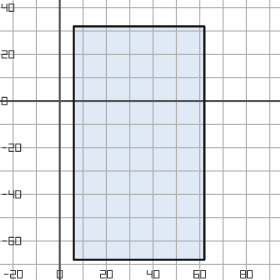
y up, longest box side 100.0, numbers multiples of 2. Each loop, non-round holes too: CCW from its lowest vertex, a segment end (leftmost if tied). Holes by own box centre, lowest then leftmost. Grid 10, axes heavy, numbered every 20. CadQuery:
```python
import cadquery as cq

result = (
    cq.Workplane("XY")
    .moveTo(6.0, -68.0)
    .lineTo(62.0, -68.0)
    .lineTo(62.0, 32.0)
    .lineTo(6.0, 32.0)
    .close()
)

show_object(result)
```